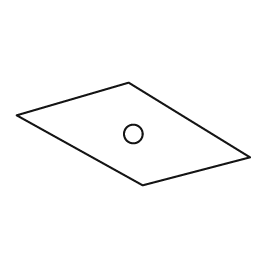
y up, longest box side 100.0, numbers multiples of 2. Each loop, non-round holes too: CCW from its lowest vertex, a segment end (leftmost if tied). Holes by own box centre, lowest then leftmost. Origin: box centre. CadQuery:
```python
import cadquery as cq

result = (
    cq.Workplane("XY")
    .moveTo(4.0, -22.0)
    .lineTo(50.0, -10.0)
    .lineTo(-2.0, 22.0)
    .lineTo(-50.0, 8.0)
    .close()
    .moveTo(0.0, 0.0)
    .circle(4.0)
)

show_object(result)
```